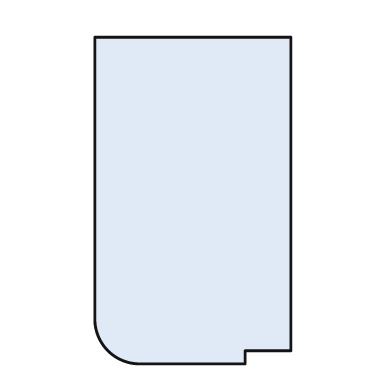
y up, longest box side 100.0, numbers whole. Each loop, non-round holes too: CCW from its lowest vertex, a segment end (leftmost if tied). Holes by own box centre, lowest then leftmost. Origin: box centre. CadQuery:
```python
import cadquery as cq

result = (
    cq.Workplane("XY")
    .moveTo(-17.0, -50.0)
    .lineTo(16.0, -50.0)
    .lineTo(16.0, -46.0)
    .lineTo(30.0, -46.0)
    .lineTo(30.0, 50.0)
    .lineTo(-30.0, 50.0)
    .lineTo(-30.0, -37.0)
    .threePointArc((-26.0, -46.0), (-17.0, -50.0))
    .close()
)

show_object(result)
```